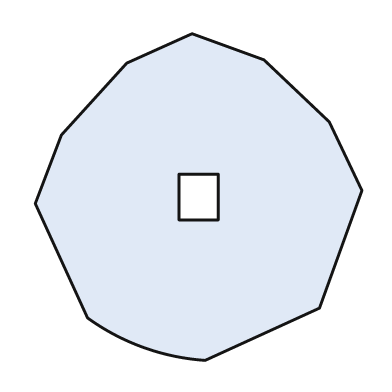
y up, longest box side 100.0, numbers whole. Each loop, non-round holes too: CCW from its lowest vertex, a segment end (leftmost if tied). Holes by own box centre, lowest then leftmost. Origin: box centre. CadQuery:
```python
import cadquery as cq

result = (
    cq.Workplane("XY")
    .moveTo(2.0, -50.0)
    .lineTo(37.0, -34.0)
    .lineTo(50.0, 2.0)
    .lineTo(40.0, 23.0)
    .lineTo(20.0, 42.0)
    .lineTo(-2.0, 50.0)
    .lineTo(-22.0, 41.0)
    .lineTo(-42.0, 19.0)
    .lineTo(-50.0, -2.0)
    .lineTo(-34.0, -37.0)
    .threePointArc((-17.0, -46.0), (2.0, -50.0))
    .close()
    .moveTo(-6.0, -7.0)
    .lineTo(6.0, -7.0)
    .lineTo(6.0, 7.0)
    .lineTo(-6.0, 7.0)
    .close()
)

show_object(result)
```